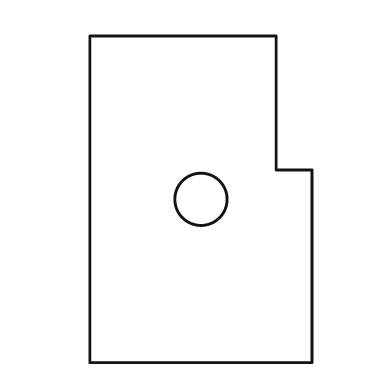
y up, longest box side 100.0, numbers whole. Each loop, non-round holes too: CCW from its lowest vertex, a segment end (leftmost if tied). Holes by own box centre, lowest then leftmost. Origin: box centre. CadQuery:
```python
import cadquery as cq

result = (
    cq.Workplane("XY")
    .moveTo(-34.0, -50.0)
    .lineTo(34.0, -50.0)
    .lineTo(34.0, 9.0)
    .lineTo(23.0, 9.0)
    .lineTo(23.0, 50.0)
    .lineTo(-34.0, 50.0)
    .close()
    .moveTo(0.0, 0.0)
    .circle(8.0)
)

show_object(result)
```